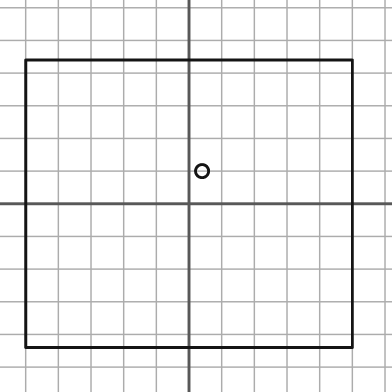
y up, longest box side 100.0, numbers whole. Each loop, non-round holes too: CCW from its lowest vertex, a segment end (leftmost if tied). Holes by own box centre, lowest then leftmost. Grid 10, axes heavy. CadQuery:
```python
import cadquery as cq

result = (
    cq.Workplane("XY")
    .moveTo(-50.0, -44.0)
    .lineTo(50.0, -44.0)
    .lineTo(50.0, 44.0)
    .lineTo(-50.0, 44.0)
    .close()
    .moveTo(4.0, 10.0)
    .circle(2.0)
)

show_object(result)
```